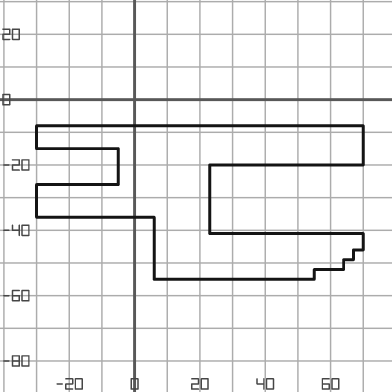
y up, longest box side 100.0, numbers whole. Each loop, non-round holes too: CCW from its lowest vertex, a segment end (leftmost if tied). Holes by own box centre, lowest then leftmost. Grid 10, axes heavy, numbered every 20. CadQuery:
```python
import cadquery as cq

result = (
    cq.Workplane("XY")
    .moveTo(6.0, -55.0)
    .lineTo(55.0, -55.0)
    .lineTo(55.0, -52.0)
    .lineTo(64.0, -52.0)
    .lineTo(64.0, -49.0)
    .lineTo(67.0, -49.0)
    .lineTo(67.0, -46.0)
    .lineTo(70.0, -46.0)
    .lineTo(70.0, -41.0)
    .lineTo(23.0, -41.0)
    .lineTo(23.0, -20.0)
    .lineTo(70.0, -20.0)
    .lineTo(70.0, -8.0)
    .lineTo(-30.0, -8.0)
    .lineTo(-30.0, -15.0)
    .lineTo(-5.0, -15.0)
    .lineTo(-5.0, -26.0)
    .lineTo(-30.0, -26.0)
    .lineTo(-30.0, -36.0)
    .lineTo(6.0, -36.0)
    .close()
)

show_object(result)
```